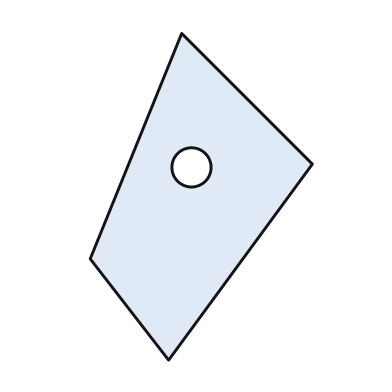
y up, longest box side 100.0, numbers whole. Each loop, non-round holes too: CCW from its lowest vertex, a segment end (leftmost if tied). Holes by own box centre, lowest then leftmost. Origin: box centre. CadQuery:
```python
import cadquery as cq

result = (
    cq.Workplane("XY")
    .moveTo(-10.0, -50.0)
    .lineTo(34.0, 10.0)
    .lineTo(-6.0, 50.0)
    .lineTo(-34.0, -19.0)
    .close()
    .moveTo(-3.0, 9.0)
    .circle(6.0)
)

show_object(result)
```